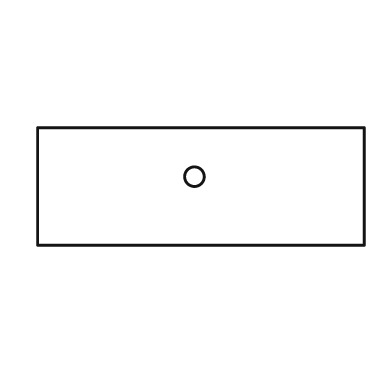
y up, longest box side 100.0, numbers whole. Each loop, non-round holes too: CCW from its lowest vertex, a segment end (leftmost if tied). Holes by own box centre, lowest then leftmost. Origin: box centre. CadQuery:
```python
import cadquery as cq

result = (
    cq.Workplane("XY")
    .moveTo(-50.0, -18.0)
    .lineTo(50.0, -18.0)
    .lineTo(50.0, 18.0)
    .lineTo(-50.0, 18.0)
    .close()
    .moveTo(-2.0, 3.0)
    .circle(3.0)
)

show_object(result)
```